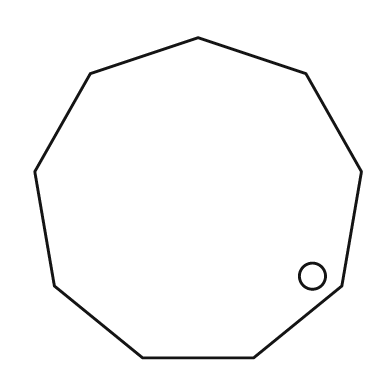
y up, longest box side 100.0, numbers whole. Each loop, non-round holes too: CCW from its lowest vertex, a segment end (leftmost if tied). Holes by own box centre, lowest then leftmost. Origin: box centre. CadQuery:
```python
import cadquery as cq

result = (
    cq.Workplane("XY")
    .moveTo(-17.0, -49.0)
    .lineTo(17.0, -49.0)
    .lineTo(44.0, -27.0)
    .lineTo(50.0, 8.0)
    .lineTo(33.0, 38.0)
    .lineTo(0.0, 49.0)
    .lineTo(-33.0, 38.0)
    .lineTo(-50.0, 8.0)
    .lineTo(-44.0, -27.0)
    .close()
    .moveTo(35.0, -24.0)
    .circle(4.0)
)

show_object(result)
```